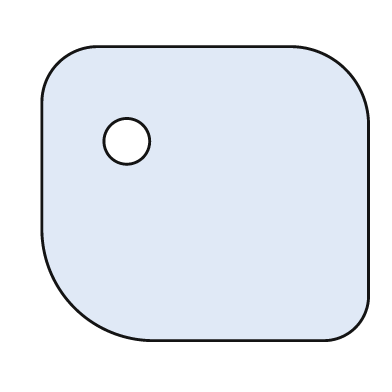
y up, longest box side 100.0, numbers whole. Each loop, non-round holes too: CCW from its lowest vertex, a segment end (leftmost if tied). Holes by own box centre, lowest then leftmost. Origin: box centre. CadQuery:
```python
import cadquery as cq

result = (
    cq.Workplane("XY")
    .moveTo(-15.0, -45.0)
    .lineTo(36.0, -45.0)
    .threePointArc((46.0, -41.0), (50.0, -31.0))
    .lineTo(50.0, 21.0)
    .threePointArc((43.0, 38.0), (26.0, 45.0))
    .lineTo(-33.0, 45.0)
    .threePointArc((-45.0, 40.0), (-50.0, 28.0))
    .lineTo(-50.0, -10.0)
    .threePointArc((-40.0, -35.0), (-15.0, -45.0))
    .close()
    .moveTo(-24.0, 16.0)
    .circle(7.0)
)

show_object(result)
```